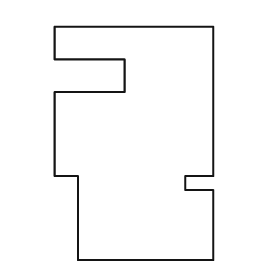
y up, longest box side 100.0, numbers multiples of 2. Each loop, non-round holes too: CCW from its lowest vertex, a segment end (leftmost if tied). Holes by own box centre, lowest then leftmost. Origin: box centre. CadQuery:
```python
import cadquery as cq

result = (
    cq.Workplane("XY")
    .moveTo(-24.0, -50.0)
    .lineTo(34.0, -50.0)
    .lineTo(34.0, -20.0)
    .lineTo(22.0, -20.0)
    .lineTo(22.0, -14.0)
    .lineTo(34.0, -14.0)
    .lineTo(34.0, 50.0)
    .lineTo(-34.0, 50.0)
    .lineTo(-34.0, 36.0)
    .lineTo(-4.0, 36.0)
    .lineTo(-4.0, 22.0)
    .lineTo(-34.0, 22.0)
    .lineTo(-34.0, -14.0)
    .lineTo(-24.0, -14.0)
    .close()
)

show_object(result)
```